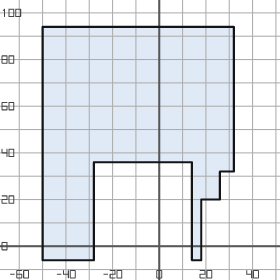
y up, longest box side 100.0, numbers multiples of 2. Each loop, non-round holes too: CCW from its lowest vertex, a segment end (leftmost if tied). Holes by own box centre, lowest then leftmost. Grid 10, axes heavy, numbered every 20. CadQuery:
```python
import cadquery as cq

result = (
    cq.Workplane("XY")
    .moveTo(-50.0, -6.0)
    .lineTo(-28.0, -6.0)
    .lineTo(-28.0, 36.0)
    .lineTo(14.0, 36.0)
    .lineTo(14.0, -6.0)
    .lineTo(18.0, -6.0)
    .lineTo(18.0, 20.0)
    .lineTo(26.0, 20.0)
    .lineTo(26.0, 32.0)
    .lineTo(32.0, 32.0)
    .lineTo(32.0, 94.0)
    .lineTo(-50.0, 94.0)
    .close()
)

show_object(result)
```